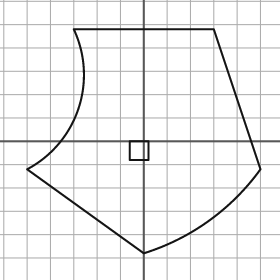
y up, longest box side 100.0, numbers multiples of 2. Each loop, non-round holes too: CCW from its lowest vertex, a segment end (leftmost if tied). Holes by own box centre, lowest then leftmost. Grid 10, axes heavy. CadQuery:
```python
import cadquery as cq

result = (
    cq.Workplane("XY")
    .moveTo(0.0, -48.0)
    .threePointArc((28.0, -34.0), (50.0, -12.0))
    .lineTo(30.0, 48.0)
    .lineTo(-30.0, 48.0)
    .threePointArc((-28.0, 14.0), (-50.0, -12.0))
    .close()
    .moveTo(-6.0, -8.0)
    .lineTo(2.0, -8.0)
    .lineTo(2.0, 0.0)
    .lineTo(-6.0, 0.0)
    .close()
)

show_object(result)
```